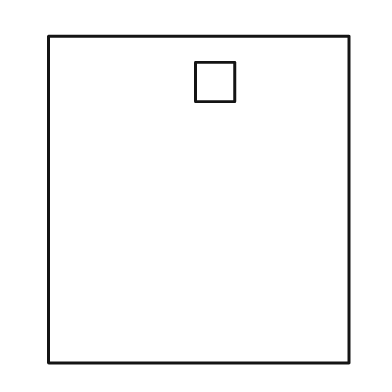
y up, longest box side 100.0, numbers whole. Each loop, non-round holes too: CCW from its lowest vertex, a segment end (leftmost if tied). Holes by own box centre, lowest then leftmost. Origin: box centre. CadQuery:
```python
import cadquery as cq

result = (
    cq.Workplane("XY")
    .moveTo(-46.0, -50.0)
    .lineTo(46.0, -50.0)
    .lineTo(46.0, 50.0)
    .lineTo(-46.0, 50.0)
    .close()
    .moveTo(-1.0, 30.0)
    .lineTo(11.0, 30.0)
    .lineTo(11.0, 42.0)
    .lineTo(-1.0, 42.0)
    .close()
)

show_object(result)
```